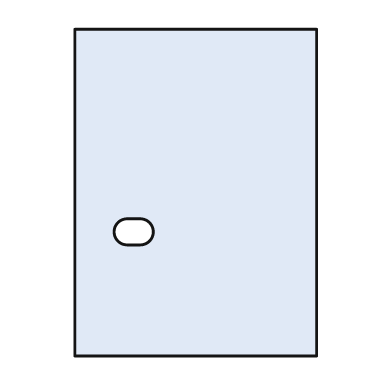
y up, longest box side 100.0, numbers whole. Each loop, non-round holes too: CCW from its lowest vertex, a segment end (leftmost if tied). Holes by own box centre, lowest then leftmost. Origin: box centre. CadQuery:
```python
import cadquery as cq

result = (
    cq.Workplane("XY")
    .moveTo(-37.0, -50.0)
    .lineTo(37.0, -50.0)
    .lineTo(37.0, 50.0)
    .lineTo(-37.0, 50.0)
    .close()
    .moveTo(-21.0, -16.0)
    .lineTo(-17.0, -16.0)
    .threePointArc((-13.0, -12.0), (-17.0, -8.0))
    .lineTo(-21.0, -8.0)
    .threePointArc((-25.0, -12.0), (-21.0, -16.0))
    .close()
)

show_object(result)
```